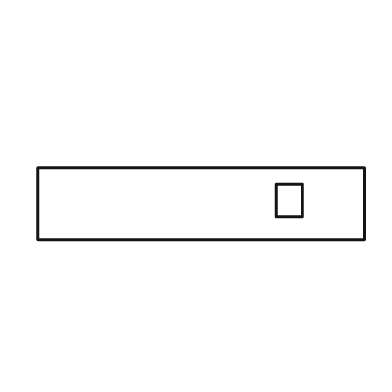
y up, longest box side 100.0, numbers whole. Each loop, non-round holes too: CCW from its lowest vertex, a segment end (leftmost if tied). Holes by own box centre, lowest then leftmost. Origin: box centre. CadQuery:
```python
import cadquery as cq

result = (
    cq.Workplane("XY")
    .moveTo(-50.0, -11.0)
    .lineTo(50.0, -11.0)
    .lineTo(50.0, 11.0)
    .lineTo(-50.0, 11.0)
    .close()
    .moveTo(23.0, -4.0)
    .lineTo(31.0, -4.0)
    .lineTo(31.0, 6.0)
    .lineTo(23.0, 6.0)
    .close()
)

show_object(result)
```